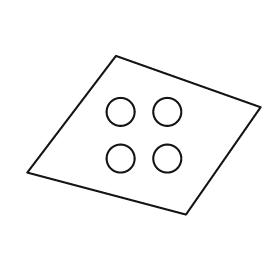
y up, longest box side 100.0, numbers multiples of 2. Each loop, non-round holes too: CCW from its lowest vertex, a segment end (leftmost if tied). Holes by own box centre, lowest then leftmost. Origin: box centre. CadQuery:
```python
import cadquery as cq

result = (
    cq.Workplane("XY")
    .moveTo(18.0, -34.0)
    .lineTo(50.0, 12.0)
    .lineTo(-12.0, 34.0)
    .lineTo(-50.0, -16.0)
    .close()
    .moveTo(-10.0, -10.0)
    .circle(6.0)
    .moveTo(10.0, -10.0)
    .circle(6.0)
    .moveTo(-10.0, 10.0)
    .circle(6.0)
    .moveTo(10.0, 10.0)
    .circle(6.0)
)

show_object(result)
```